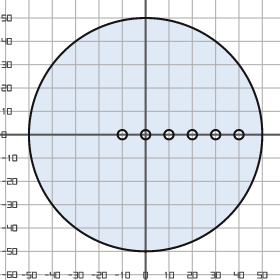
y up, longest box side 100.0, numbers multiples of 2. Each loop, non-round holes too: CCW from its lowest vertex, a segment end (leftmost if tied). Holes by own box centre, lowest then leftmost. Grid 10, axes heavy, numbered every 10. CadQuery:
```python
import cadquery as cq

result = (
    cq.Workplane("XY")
    .moveTo(0.0, 0.0)
    .circle(50.0)
    .moveTo(-10.0, 0.0)
    .circle(2.0)
    .moveTo(0.0, 0.0)
    .circle(2.0)
    .moveTo(10.0, 0.0)
    .circle(2.0)
    .moveTo(20.0, 0.0)
    .circle(2.0)
    .moveTo(30.0, 0.0)
    .circle(2.0)
    .moveTo(40.0, 0.0)
    .circle(2.0)
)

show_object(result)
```